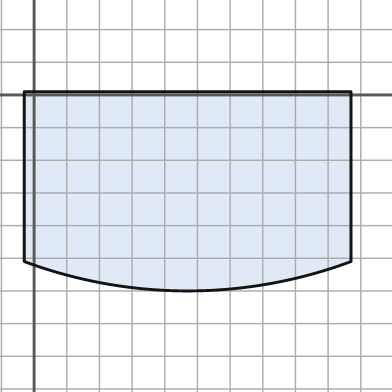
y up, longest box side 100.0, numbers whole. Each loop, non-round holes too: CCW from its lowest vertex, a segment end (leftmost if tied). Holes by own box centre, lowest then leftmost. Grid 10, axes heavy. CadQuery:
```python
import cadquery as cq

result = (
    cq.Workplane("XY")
    .moveTo(-3.0, -51.0)
    .threePointArc((47.0, -60.0), (97.0, -51.0))
    .lineTo(97.0, 1.0)
    .lineTo(-3.0, 1.0)
    .close()
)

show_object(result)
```